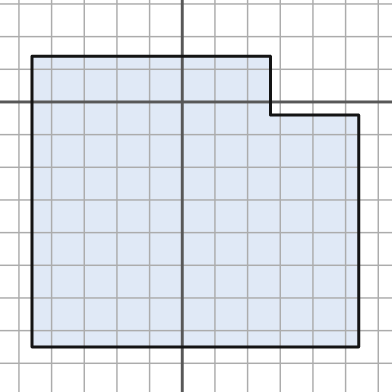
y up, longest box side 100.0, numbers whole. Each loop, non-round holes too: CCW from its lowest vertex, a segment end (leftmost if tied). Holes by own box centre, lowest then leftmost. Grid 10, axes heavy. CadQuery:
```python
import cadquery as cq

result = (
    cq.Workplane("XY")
    .moveTo(-46.0, -75.0)
    .lineTo(54.0, -75.0)
    .lineTo(54.0, -4.0)
    .lineTo(27.0, -4.0)
    .lineTo(27.0, 14.0)
    .lineTo(-46.0, 14.0)
    .close()
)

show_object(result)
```